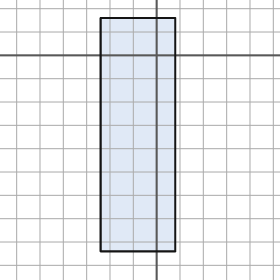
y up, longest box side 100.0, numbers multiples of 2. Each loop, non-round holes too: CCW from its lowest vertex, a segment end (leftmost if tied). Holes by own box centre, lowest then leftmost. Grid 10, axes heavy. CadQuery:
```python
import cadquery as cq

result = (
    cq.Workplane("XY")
    .moveTo(-24.0, -84.0)
    .lineTo(8.0, -84.0)
    .lineTo(8.0, 16.0)
    .lineTo(-24.0, 16.0)
    .close()
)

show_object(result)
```